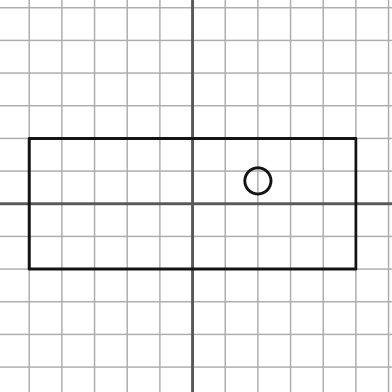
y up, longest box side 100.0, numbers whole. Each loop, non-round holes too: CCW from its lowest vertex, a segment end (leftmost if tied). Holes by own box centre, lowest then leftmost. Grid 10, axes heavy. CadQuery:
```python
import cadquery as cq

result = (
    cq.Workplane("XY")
    .moveTo(-50.0, -20.0)
    .lineTo(50.0, -20.0)
    .lineTo(50.0, 20.0)
    .lineTo(-50.0, 20.0)
    .close()
    .moveTo(20.0, 7.0)
    .circle(4.0)
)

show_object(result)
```